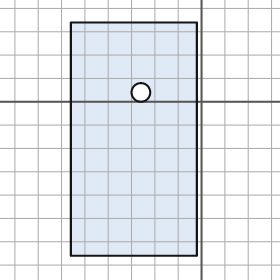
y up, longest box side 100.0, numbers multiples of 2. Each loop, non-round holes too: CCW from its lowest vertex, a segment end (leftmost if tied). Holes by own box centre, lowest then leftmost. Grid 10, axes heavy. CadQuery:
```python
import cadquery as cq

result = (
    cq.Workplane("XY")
    .moveTo(-56.0, -66.0)
    .lineTo(-2.0, -66.0)
    .lineTo(-2.0, 34.0)
    .lineTo(-56.0, 34.0)
    .close()
    .moveTo(-26.0, 4.0)
    .circle(4.0)
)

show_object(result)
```